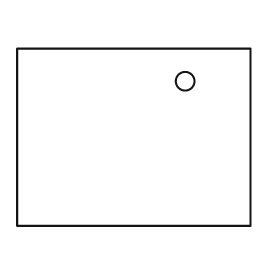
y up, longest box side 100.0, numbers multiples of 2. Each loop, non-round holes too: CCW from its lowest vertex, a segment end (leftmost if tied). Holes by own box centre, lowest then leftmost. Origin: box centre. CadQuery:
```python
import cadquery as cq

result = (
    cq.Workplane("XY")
    .moveTo(-50.0, -38.0)
    .lineTo(50.0, -38.0)
    .lineTo(50.0, 38.0)
    .lineTo(-50.0, 38.0)
    .close()
    .moveTo(22.0, 24.0)
    .circle(4.0)
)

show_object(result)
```